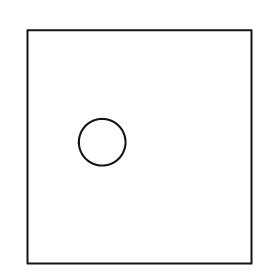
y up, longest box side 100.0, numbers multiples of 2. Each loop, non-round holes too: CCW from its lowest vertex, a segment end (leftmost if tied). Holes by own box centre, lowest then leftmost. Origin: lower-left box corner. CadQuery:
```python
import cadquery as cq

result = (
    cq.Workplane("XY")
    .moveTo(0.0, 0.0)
    .lineTo(96.0, 0.0)
    .lineTo(96.0, 100.0)
    .lineTo(0.0, 100.0)
    .close()
    .moveTo(32.0, 52.0)
    .circle(10.0)
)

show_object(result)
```